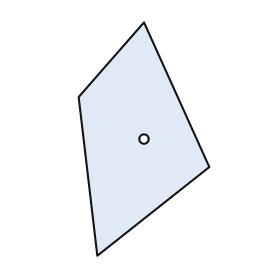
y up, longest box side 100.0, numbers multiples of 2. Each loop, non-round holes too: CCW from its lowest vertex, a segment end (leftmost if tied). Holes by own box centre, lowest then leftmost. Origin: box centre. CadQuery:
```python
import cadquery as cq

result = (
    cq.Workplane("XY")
    .moveTo(-20.0, -50.0)
    .lineTo(28.0, -12.0)
    .lineTo(0.0, 50.0)
    .lineTo(-28.0, 18.0)
    .close()
    .moveTo(0.0, 0.0)
    .circle(2.0)
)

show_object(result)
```